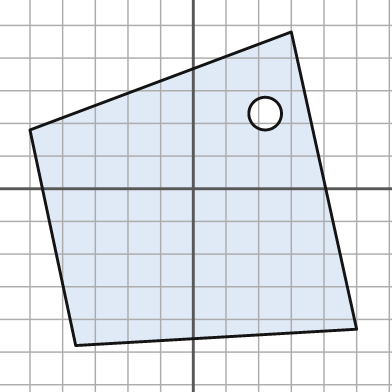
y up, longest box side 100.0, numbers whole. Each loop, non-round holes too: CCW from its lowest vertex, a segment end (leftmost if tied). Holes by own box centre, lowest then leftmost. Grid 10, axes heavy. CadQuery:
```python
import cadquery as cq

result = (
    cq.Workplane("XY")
    .moveTo(-36.0, -48.0)
    .lineTo(50.0, -43.0)
    .lineTo(30.0, 48.0)
    .lineTo(-50.0, 18.0)
    .close()
    .moveTo(22.0, 23.0)
    .circle(5.0)
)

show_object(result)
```